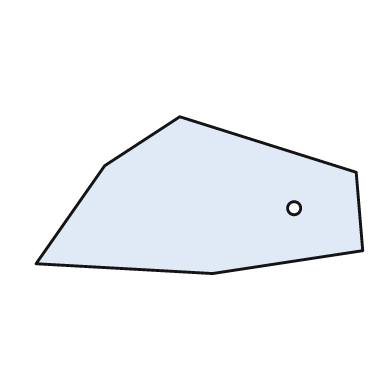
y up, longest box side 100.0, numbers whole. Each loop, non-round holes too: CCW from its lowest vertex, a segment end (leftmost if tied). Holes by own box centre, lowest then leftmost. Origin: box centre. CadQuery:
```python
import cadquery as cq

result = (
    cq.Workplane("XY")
    .moveTo(4.0, -24.0)
    .lineTo(50.0, -17.0)
    .lineTo(48.0, 7.0)
    .lineTo(-6.0, 24.0)
    .lineTo(-29.0, 9.0)
    .lineTo(-50.0, -21.0)
    .close()
    .moveTo(29.0, -4.0)
    .circle(2.0)
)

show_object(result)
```